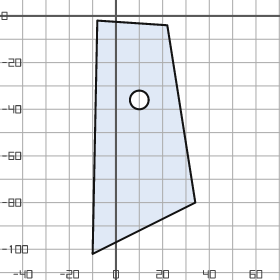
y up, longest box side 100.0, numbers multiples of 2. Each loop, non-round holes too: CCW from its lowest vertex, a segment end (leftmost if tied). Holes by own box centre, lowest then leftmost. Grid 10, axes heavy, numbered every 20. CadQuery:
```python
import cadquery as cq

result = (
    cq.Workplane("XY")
    .moveTo(-10.0, -102.0)
    .lineTo(34.0, -80.0)
    .lineTo(22.0, -4.0)
    .lineTo(-8.0, -2.0)
    .close()
    .moveTo(10.0, -36.0)
    .circle(4.0)
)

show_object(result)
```